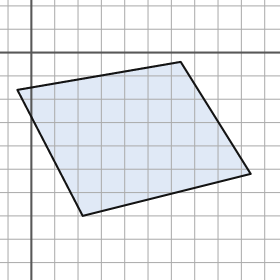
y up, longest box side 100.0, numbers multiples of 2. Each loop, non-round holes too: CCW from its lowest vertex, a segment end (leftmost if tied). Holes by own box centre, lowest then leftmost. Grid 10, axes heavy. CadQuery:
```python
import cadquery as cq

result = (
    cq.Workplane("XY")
    .moveTo(22.0, -70.0)
    .lineTo(94.0, -52.0)
    .lineTo(64.0, -4.0)
    .lineTo(-6.0, -16.0)
    .close()
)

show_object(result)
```